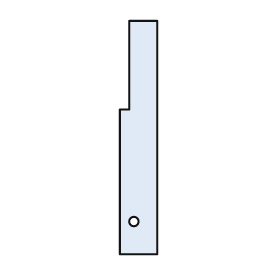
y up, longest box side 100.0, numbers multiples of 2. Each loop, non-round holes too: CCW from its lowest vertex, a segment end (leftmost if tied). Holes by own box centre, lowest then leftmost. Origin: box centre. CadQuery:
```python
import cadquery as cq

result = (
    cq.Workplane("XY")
    .moveTo(-8.0, -50.0)
    .lineTo(8.0, -50.0)
    .lineTo(8.0, 50.0)
    .lineTo(-4.0, 50.0)
    .lineTo(-4.0, 12.0)
    .lineTo(-8.0, 12.0)
    .close()
    .moveTo(-2.0, -36.0)
    .circle(2.0)
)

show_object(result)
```